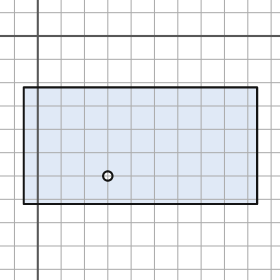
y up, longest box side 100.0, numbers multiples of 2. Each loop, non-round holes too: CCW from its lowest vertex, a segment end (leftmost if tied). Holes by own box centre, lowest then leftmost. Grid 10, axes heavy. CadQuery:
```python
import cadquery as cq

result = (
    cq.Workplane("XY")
    .moveTo(-6.0, -72.0)
    .lineTo(94.0, -72.0)
    .lineTo(94.0, -22.0)
    .lineTo(-6.0, -22.0)
    .close()
    .moveTo(30.0, -60.0)
    .circle(2.0)
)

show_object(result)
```